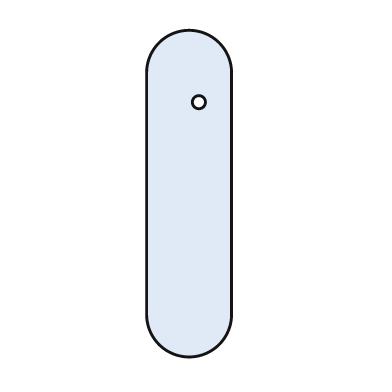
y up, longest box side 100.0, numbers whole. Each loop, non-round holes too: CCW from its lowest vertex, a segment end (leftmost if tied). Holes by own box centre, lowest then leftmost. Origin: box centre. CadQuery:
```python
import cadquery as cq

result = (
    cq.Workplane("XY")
    .moveTo(-13.0, -37.0)
    .threePointArc((0.0, -50.0), (13.0, -37.0))
    .lineTo(13.0, 37.0)
    .threePointArc((0.0, 50.0), (-13.0, 37.0))
    .close()
    .moveTo(3.0, 28.0)
    .circle(2.0)
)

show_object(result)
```